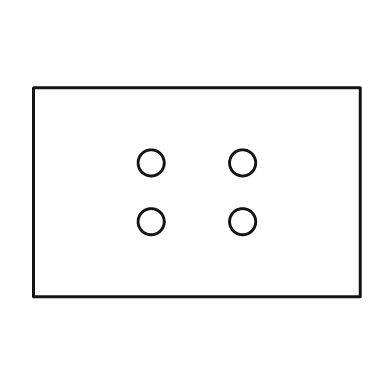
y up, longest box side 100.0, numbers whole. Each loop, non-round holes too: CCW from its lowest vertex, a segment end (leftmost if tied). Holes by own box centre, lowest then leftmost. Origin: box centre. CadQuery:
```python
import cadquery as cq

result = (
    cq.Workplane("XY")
    .moveTo(-50.0, -32.0)
    .lineTo(50.0, -32.0)
    .lineTo(50.0, 32.0)
    .lineTo(-50.0, 32.0)
    .close()
    .moveTo(-14.0, -9.0)
    .circle(4.0)
    .moveTo(14.0, -9.0)
    .circle(4.0)
    .moveTo(-14.0, 9.0)
    .circle(4.0)
    .moveTo(14.0, 9.0)
    .circle(4.0)
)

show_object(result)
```